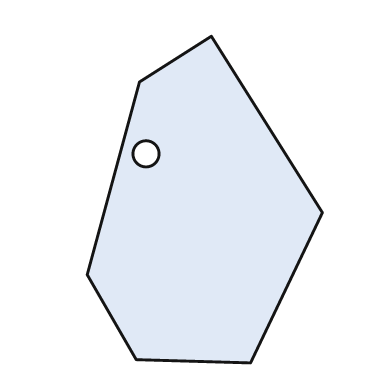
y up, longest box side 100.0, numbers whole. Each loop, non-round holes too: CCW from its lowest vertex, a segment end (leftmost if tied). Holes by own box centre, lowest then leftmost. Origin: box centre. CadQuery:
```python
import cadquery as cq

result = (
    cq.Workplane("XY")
    .moveTo(14.0, -50.0)
    .lineTo(36.0, -4.0)
    .lineTo(2.0, 50.0)
    .lineTo(-20.0, 36.0)
    .lineTo(-36.0, -23.0)
    .lineTo(-21.0, -49.0)
    .close()
    .moveTo(-18.0, 14.0)
    .circle(4.0)
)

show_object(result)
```